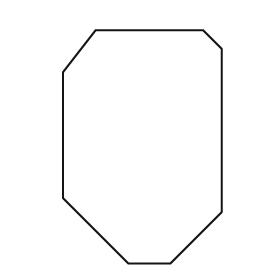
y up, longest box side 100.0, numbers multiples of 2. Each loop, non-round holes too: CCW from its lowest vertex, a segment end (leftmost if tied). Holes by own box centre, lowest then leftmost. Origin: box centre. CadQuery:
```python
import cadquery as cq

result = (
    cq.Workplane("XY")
    .moveTo(-6.0, -50.0)
    .lineTo(12.0, -50.0)
    .lineTo(34.0, -28.0)
    .lineTo(34.0, 42.0)
    .lineTo(26.0, 50.0)
    .lineTo(-20.0, 50.0)
    .lineTo(-34.0, 32.0)
    .lineTo(-34.0, -22.0)
    .close()
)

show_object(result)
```